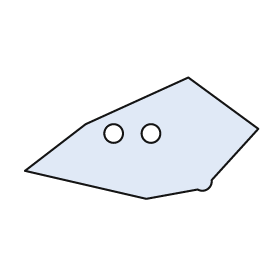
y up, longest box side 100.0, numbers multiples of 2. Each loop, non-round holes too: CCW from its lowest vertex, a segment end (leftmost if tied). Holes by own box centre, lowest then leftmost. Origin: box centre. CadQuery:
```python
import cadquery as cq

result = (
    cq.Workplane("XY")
    .moveTo(2.0, -26.0)
    .lineTo(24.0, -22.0)
    .threePointArc((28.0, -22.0), (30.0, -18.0))
    .lineTo(50.0, 4.0)
    .lineTo(20.0, 26.0)
    .lineTo(-24.0, 6.0)
    .lineTo(-50.0, -14.0)
    .close()
    .moveTo(-12.0, 2.0)
    .circle(4.0)
    .moveTo(4.0, 2.0)
    .circle(4.0)
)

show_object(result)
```